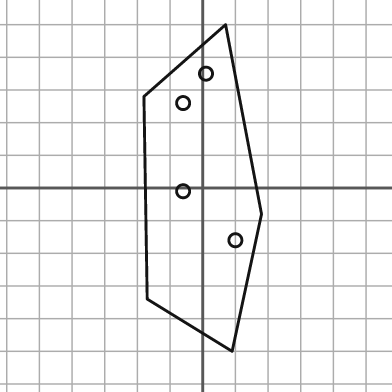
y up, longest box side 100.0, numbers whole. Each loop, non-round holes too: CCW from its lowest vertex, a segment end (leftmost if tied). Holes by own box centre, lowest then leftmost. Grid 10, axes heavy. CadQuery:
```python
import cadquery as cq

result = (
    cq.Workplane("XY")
    .moveTo(9.0, -50.0)
    .lineTo(18.0, -8.0)
    .lineTo(7.0, 50.0)
    .lineTo(-18.0, 28.0)
    .lineTo(-17.0, -34.0)
    .close()
    .moveTo(10.0, -16.0)
    .circle(2.0)
    .moveTo(-6.0, -1.0)
    .circle(2.0)
    .moveTo(-6.0, 26.0)
    .circle(2.0)
    .moveTo(1.0, 35.0)
    .circle(2.0)
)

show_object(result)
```